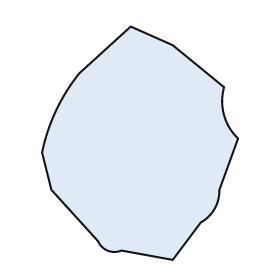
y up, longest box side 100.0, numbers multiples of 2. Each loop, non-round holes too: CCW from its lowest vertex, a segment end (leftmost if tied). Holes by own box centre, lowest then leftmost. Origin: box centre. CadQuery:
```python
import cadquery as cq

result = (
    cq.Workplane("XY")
    .moveTo(14.0, -50.0)
    .lineTo(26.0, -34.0)
    .threePointArc((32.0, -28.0), (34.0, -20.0))
    .lineTo(42.0, 2.0)
    .threePointArc((36.0, 12.0), (36.0, 24.0))
    .lineTo(14.0, 42.0)
    .lineTo(-4.0, 50.0)
    .lineTo(-26.0, 30.0)
    .threePointArc((-36.0, 14.0), (-42.0, -4.0))
    .lineTo(-38.0, -20.0)
    .lineTo(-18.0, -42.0)
    .threePointArc((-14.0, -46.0), (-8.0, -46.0))
    .close()
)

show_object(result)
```